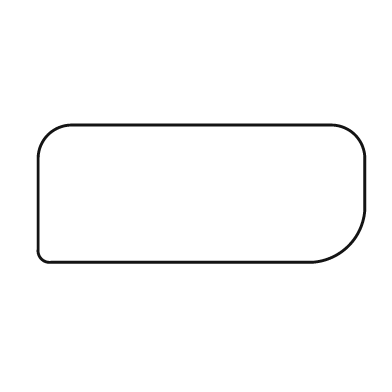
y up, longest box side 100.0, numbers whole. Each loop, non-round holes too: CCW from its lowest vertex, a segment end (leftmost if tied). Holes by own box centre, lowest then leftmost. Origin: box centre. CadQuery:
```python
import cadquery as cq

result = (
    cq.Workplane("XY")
    .moveTo(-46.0, -21.0)
    .lineTo(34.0, -21.0)
    .threePointArc((45.0, -16.0), (50.0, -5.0))
    .lineTo(50.0, 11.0)
    .threePointArc((47.0, 18.0), (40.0, 21.0))
    .lineTo(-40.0, 21.0)
    .threePointArc((-47.0, 18.0), (-50.0, 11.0))
    .lineTo(-50.0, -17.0)
    .threePointArc((-49.0, -20.0), (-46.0, -21.0))
    .close()
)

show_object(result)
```